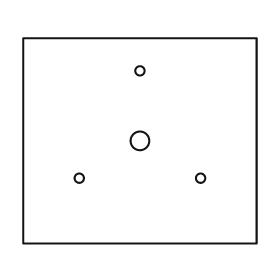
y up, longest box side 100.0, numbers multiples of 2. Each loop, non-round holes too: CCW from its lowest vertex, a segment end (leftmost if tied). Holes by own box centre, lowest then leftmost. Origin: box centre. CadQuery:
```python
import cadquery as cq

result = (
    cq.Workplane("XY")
    .moveTo(-50.0, -44.0)
    .lineTo(50.0, -44.0)
    .lineTo(50.0, 44.0)
    .lineTo(-50.0, 44.0)
    .close()
    .moveTo(-26.0, -16.0)
    .circle(2.0)
    .moveTo(26.0, -16.0)
    .circle(2.0)
    .moveTo(0.0, 0.0)
    .circle(4.0)
    .moveTo(0.0, 30.0)
    .circle(2.0)
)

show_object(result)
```